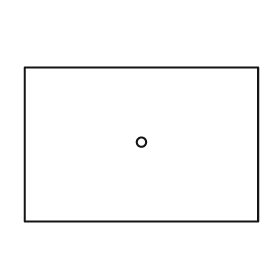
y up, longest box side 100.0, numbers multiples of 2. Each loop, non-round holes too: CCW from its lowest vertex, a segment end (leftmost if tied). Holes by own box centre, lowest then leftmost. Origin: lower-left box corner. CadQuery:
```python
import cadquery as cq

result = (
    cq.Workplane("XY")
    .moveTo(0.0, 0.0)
    .lineTo(100.0, 0.0)
    .lineTo(100.0, 66.0)
    .lineTo(0.0, 66.0)
    .close()
    .moveTo(50.0, 34.0)
    .circle(2.0)
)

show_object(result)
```